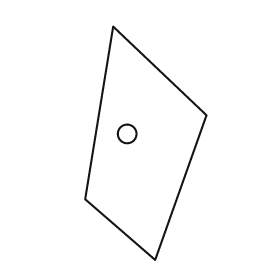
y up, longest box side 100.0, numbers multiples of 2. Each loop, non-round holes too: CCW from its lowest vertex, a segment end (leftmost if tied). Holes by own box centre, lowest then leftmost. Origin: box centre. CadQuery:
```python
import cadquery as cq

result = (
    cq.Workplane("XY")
    .moveTo(4.0, -50.0)
    .lineTo(26.0, 12.0)
    .lineTo(-14.0, 50.0)
    .lineTo(-26.0, -24.0)
    .close()
    .moveTo(-8.0, 4.0)
    .circle(4.0)
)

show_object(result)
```